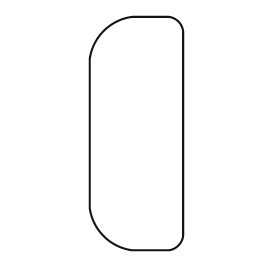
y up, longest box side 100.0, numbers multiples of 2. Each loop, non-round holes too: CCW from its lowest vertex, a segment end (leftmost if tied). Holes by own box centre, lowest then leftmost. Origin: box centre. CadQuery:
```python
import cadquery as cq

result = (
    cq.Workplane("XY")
    .moveTo(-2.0, -50.0)
    .lineTo(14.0, -50.0)
    .threePointArc((18.0, -48.0), (20.0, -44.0))
    .lineTo(20.0, 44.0)
    .threePointArc((18.0, 48.0), (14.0, 50.0))
    .lineTo(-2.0, 50.0)
    .threePointArc((-14.0, 44.0), (-20.0, 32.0))
    .lineTo(-20.0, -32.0)
    .threePointArc((-14.0, -44.0), (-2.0, -50.0))
    .close()
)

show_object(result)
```